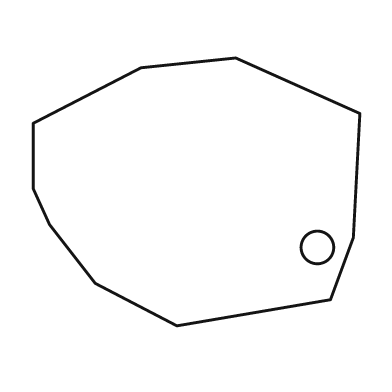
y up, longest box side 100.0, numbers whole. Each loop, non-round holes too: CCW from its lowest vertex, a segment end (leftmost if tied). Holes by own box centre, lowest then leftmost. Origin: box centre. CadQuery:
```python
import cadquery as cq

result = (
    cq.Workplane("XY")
    .moveTo(-6.0, -41.0)
    .lineTo(41.0, -33.0)
    .lineTo(48.0, -14.0)
    .lineTo(50.0, 24.0)
    .lineTo(12.0, 41.0)
    .lineTo(-17.0, 38.0)
    .lineTo(-50.0, 21.0)
    .lineTo(-50.0, 1.0)
    .lineTo(-45.0, -10.0)
    .lineTo(-31.0, -28.0)
    .close()
    .moveTo(37.0, -17.0)
    .circle(5.0)
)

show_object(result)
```